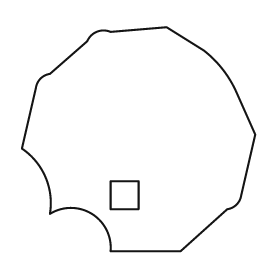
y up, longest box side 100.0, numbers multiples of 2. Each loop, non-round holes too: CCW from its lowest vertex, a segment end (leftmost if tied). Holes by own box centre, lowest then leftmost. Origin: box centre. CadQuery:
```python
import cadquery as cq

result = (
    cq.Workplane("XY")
    .moveTo(-12.0, -48.0)
    .lineTo(18.0, -48.0)
    .lineTo(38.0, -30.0)
    .threePointArc((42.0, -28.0), (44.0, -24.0))
    .lineTo(50.0, 2.0)
    .lineTo(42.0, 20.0)
    .threePointArc((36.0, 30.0), (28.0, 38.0))
    .lineTo(12.0, 48.0)
    .lineTo(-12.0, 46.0)
    .threePointArc((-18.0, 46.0), (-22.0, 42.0))
    .lineTo(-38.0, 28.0)
    .threePointArc((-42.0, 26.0), (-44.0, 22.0))
    .lineTo(-50.0, -4.0)
    .threePointArc((-40.0, -16.0), (-38.0, -32.0))
    .threePointArc((-20.0, -32.0), (-12.0, -48.0))
    .close()
    .moveTo(-12.0, -30.0)
    .lineTo(0.0, -30.0)
    .lineTo(0.0, -18.0)
    .lineTo(-12.0, -18.0)
    .close()
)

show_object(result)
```